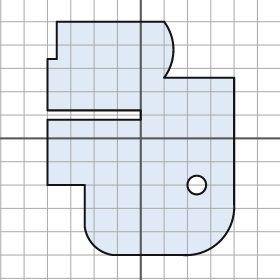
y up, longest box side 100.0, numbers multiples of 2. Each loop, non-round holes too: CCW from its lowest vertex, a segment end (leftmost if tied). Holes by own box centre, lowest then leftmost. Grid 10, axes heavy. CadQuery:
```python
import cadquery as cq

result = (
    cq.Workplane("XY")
    .moveTo(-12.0, -50.0)
    .lineTo(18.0, -50.0)
    .threePointArc((34.0, -44.0), (40.0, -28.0))
    .lineTo(40.0, 26.0)
    .lineTo(10.0, 26.0)
    .threePointArc((14.0, 38.0), (10.0, 50.0))
    .lineTo(-36.0, 50.0)
    .lineTo(-36.0, 34.0)
    .lineTo(-40.0, 34.0)
    .lineTo(-40.0, 12.0)
    .lineTo(0.0, 12.0)
    .lineTo(0.0, 8.0)
    .lineTo(-40.0, 8.0)
    .lineTo(-40.0, -20.0)
    .lineTo(-24.0, -20.0)
    .lineTo(-24.0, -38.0)
    .threePointArc((-20.0, -46.0), (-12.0, -50.0))
    .close()
    .moveTo(24.0, -20.0)
    .circle(4.0)
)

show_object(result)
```